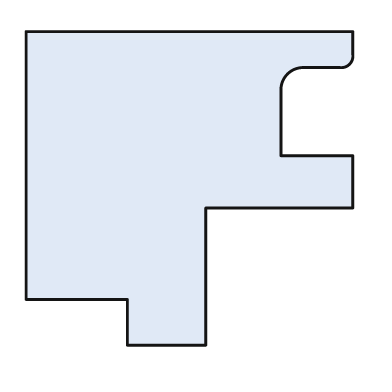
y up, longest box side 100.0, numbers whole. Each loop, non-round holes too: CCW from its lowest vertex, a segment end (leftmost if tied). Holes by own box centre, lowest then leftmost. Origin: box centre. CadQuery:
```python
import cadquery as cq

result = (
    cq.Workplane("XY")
    .moveTo(-19.0, -48.0)
    .lineTo(5.0, -48.0)
    .lineTo(5.0, -6.0)
    .lineTo(50.0, -6.0)
    .lineTo(50.0, 10.0)
    .lineTo(28.0, 10.0)
    .lineTo(28.0, 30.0)
    .threePointArc((30.0, 35.0), (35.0, 37.0))
    .lineTo(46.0, 37.0)
    .threePointArc((49.0, 38.0), (50.0, 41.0))
    .lineTo(50.0, 48.0)
    .lineTo(-50.0, 48.0)
    .lineTo(-50.0, -34.0)
    .lineTo(-19.0, -34.0)
    .close()
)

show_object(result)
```